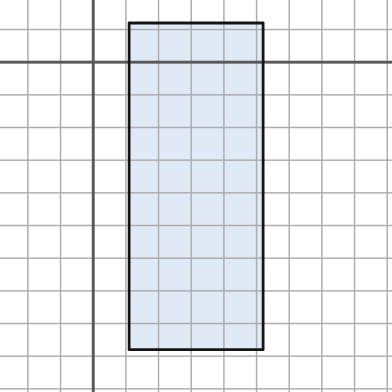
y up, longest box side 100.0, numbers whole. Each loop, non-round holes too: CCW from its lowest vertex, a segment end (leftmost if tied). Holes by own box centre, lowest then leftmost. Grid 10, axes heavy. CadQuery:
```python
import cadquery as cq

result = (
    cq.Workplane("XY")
    .moveTo(11.0, -88.0)
    .lineTo(52.0, -88.0)
    .lineTo(52.0, 12.0)
    .lineTo(11.0, 12.0)
    .close()
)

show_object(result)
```